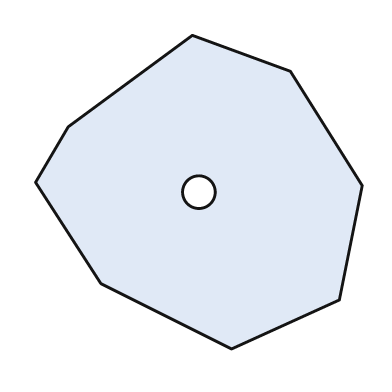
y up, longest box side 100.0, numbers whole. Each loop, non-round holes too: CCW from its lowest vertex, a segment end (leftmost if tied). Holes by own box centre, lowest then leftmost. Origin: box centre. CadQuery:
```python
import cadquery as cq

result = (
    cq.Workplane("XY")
    .moveTo(10.0, -48.0)
    .lineTo(43.0, -33.0)
    .lineTo(50.0, 2.0)
    .lineTo(28.0, 37.0)
    .lineTo(-2.0, 48.0)
    .lineTo(-40.0, 20.0)
    .lineTo(-50.0, 3.0)
    .lineTo(-30.0, -28.0)
    .close()
    .moveTo(0.0, 0.0)
    .circle(5.0)
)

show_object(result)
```